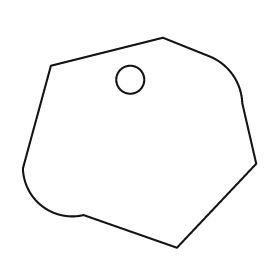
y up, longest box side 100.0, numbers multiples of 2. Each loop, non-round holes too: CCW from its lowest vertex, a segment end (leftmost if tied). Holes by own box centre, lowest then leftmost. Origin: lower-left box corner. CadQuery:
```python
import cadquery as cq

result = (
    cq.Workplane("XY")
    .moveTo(66.0, 0.0)
    .lineTo(100.0, 36.0)
    .lineTo(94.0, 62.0)
    .threePointArc((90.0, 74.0), (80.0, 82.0))
    .lineTo(60.0, 90.0)
    .lineTo(12.0, 78.0)
    .lineTo(0.0, 34.0)
    .threePointArc((8.0, 18.0), (26.0, 14.0))
    .close()
    .moveTo(46.0, 72.0)
    .circle(6.0)
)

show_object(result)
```